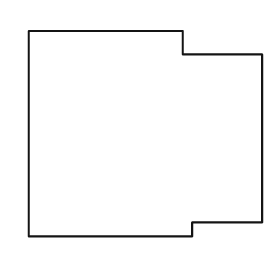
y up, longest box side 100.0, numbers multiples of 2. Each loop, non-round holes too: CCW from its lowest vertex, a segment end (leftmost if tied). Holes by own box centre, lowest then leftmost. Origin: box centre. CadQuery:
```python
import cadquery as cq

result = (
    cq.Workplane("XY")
    .moveTo(-50.0, -44.0)
    .lineTo(20.0, -44.0)
    .lineTo(20.0, -38.0)
    .lineTo(50.0, -38.0)
    .lineTo(50.0, 34.0)
    .lineTo(16.0, 34.0)
    .lineTo(16.0, 44.0)
    .lineTo(-50.0, 44.0)
    .close()
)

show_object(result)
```